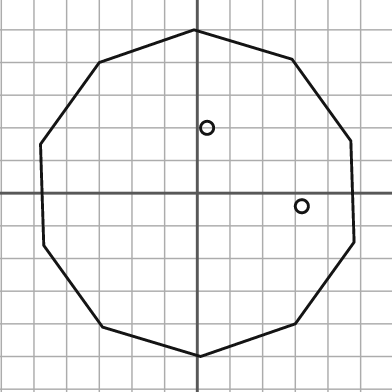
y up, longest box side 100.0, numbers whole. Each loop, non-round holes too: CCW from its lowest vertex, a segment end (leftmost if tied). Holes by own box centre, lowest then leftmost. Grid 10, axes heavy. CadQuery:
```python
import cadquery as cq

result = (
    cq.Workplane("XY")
    .moveTo(1.0, -50.0)
    .lineTo(30.0, -40.0)
    .lineTo(48.0, -15.0)
    .lineTo(47.0, 16.0)
    .lineTo(29.0, 41.0)
    .lineTo(-1.0, 50.0)
    .lineTo(-30.0, 40.0)
    .lineTo(-48.0, 15.0)
    .lineTo(-47.0, -16.0)
    .lineTo(-29.0, -41.0)
    .close()
    .moveTo(32.0, -4.0)
    .circle(2.0)
    .moveTo(3.0, 20.0)
    .circle(2.0)
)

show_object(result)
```